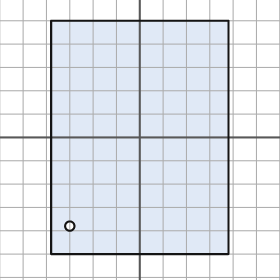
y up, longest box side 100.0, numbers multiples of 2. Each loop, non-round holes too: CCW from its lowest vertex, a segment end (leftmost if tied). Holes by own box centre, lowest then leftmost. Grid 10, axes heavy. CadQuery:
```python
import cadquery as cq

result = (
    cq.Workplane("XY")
    .moveTo(-38.0, -50.0)
    .lineTo(38.0, -50.0)
    .lineTo(38.0, 50.0)
    .lineTo(-38.0, 50.0)
    .close()
    .moveTo(-30.0, -38.0)
    .circle(2.0)
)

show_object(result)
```